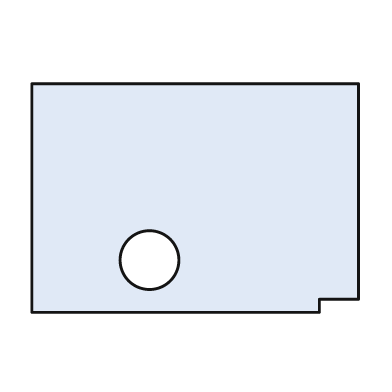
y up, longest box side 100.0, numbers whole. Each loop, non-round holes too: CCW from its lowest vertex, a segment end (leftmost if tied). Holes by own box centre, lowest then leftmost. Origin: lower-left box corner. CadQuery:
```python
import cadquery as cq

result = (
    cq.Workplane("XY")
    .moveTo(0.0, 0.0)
    .lineTo(88.0, 0.0)
    .lineTo(88.0, 4.0)
    .lineTo(100.0, 4.0)
    .lineTo(100.0, 70.0)
    .lineTo(0.0, 70.0)
    .close()
    .moveTo(36.0, 16.0)
    .circle(9.0)
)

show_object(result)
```